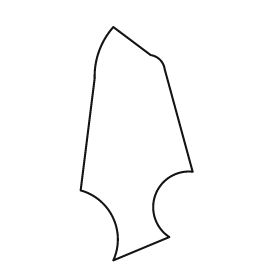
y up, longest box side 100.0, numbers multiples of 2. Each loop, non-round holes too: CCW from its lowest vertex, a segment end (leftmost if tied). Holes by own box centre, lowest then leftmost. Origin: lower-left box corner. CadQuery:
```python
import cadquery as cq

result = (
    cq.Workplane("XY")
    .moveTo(14.0, 0.0)
    .lineTo(38.0, 10.0)
    .threePointArc((32.0, 28.0), (48.0, 38.0))
    .lineTo(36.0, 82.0)
    .threePointArc((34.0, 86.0), (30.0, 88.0))
    .lineTo(14.0, 100.0)
    .threePointArc((8.0, 90.0), (6.0, 78.0))
    .lineTo(0.0, 30.0)
    .threePointArc((14.0, 18.0), (14.0, 0.0))
    .close()
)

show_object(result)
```